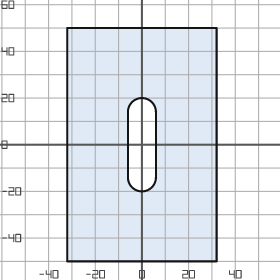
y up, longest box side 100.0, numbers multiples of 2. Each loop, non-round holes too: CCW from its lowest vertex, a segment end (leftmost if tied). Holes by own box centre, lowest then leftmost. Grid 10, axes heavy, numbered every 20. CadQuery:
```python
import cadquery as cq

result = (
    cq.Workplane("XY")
    .moveTo(-32.0, -50.0)
    .lineTo(32.0, -50.0)
    .lineTo(32.0, 50.0)
    .lineTo(-32.0, 50.0)
    .close()
    .moveTo(-6.0, -14.0)
    .threePointArc((0.0, -20.0), (6.0, -14.0))
    .lineTo(6.0, 14.0)
    .threePointArc((0.0, 20.0), (-6.0, 14.0))
    .close()
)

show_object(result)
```